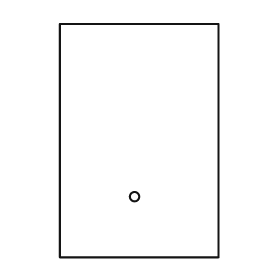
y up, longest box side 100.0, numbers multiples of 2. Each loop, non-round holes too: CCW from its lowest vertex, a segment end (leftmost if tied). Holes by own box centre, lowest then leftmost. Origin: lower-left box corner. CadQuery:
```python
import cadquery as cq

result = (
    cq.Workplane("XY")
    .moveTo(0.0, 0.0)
    .lineTo(68.0, 0.0)
    .lineTo(68.0, 100.0)
    .lineTo(0.0, 100.0)
    .close()
    .moveTo(32.0, 26.0)
    .circle(2.0)
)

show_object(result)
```